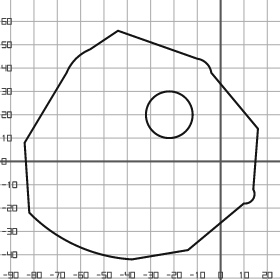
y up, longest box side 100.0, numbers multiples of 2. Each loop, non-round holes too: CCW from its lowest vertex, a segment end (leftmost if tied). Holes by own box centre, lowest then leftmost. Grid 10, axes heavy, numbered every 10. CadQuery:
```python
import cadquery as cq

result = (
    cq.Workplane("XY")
    .moveTo(-38.0, -42.0)
    .lineTo(-14.0, -38.0)
    .lineTo(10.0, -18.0)
    .threePointArc((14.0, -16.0), (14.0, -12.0))
    .lineTo(16.0, 14.0)
    .lineTo(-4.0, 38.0)
    .threePointArc((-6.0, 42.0), (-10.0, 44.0))
    .lineTo(-44.0, 56.0)
    .lineTo(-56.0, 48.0)
    .threePointArc((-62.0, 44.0), (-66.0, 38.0))
    .lineTo(-84.0, 8.0)
    .lineTo(-82.0, -22.0)
    .threePointArc((-62.0, -36.0), (-38.0, -42.0))
    .close()
    .moveTo(-22.0, 20.0)
    .circle(10.0)
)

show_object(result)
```